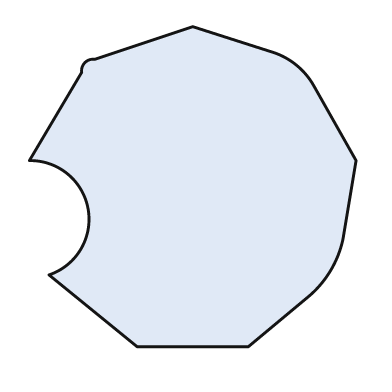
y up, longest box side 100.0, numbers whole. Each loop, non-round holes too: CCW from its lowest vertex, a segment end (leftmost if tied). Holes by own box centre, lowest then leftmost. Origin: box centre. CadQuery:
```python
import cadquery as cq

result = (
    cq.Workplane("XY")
    .moveTo(-17.0, -49.0)
    .lineTo(17.0, -49.0)
    .lineTo(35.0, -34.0)
    .threePointArc((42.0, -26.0), (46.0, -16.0))
    .lineTo(50.0, 8.0)
    .lineTo(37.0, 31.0)
    .threePointArc((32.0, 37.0), (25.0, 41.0))
    .lineTo(0.0, 49.0)
    .lineTo(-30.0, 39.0)
    .threePointArc((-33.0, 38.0), (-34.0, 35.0))
    .lineTo(-50.0, 8.0)
    .threePointArc((-32.0, -7.0), (-44.0, -27.0))
    .close()
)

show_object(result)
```